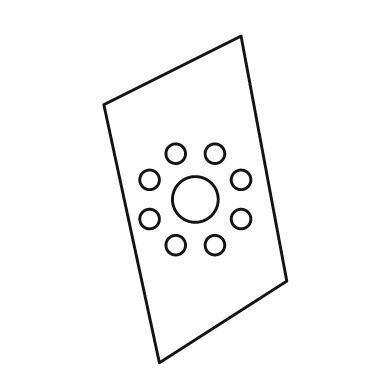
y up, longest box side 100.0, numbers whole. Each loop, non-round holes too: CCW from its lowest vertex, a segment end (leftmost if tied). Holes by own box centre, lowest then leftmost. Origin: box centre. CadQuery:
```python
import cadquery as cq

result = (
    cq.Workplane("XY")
    .moveTo(-11.0, -50.0)
    .lineTo(28.0, -25.0)
    .lineTo(14.0, 50.0)
    .lineTo(-28.0, 29.0)
    .close()
    .moveTo(-6.0, -14.0)
    .circle(3.0)
    .moveTo(6.0, -14.0)
    .circle(3.0)
    .moveTo(-14.0, -6.0)
    .circle(3.0)
    .moveTo(14.0, -6.0)
    .circle(3.0)
    .moveTo(0.0, 0.0)
    .circle(7.0)
    .moveTo(-14.0, 6.0)
    .circle(3.0)
    .moveTo(14.0, 6.0)
    .circle(3.0)
    .moveTo(-6.0, 14.0)
    .circle(3.0)
    .moveTo(6.0, 14.0)
    .circle(3.0)
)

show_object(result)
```